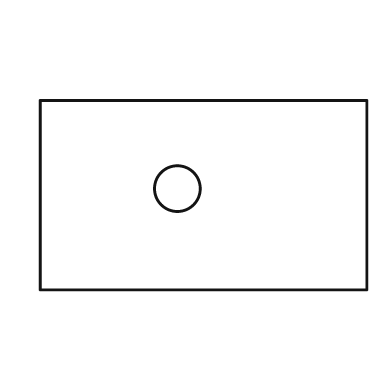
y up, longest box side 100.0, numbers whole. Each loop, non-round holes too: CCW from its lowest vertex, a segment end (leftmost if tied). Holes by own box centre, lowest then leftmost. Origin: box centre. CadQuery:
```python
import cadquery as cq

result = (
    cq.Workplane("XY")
    .moveTo(-50.0, -29.0)
    .lineTo(50.0, -29.0)
    .lineTo(50.0, 29.0)
    .lineTo(-50.0, 29.0)
    .close()
    .moveTo(-8.0, 2.0)
    .circle(7.0)
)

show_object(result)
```